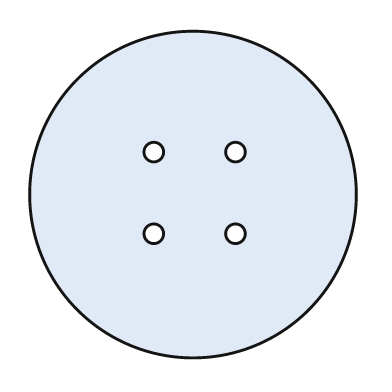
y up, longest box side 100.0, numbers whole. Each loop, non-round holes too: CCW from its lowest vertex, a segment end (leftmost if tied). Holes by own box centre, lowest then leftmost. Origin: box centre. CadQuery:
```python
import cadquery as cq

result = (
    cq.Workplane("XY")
    .moveTo(0.0, 0.0)
    .circle(50.0)
    .moveTo(-12.0, -12.0)
    .circle(3.0)
    .moveTo(13.0, -12.0)
    .circle(3.0)
    .moveTo(-12.0, 13.0)
    .circle(3.0)
    .moveTo(13.0, 13.0)
    .circle(3.0)
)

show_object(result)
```